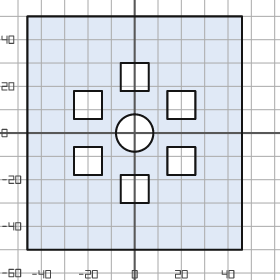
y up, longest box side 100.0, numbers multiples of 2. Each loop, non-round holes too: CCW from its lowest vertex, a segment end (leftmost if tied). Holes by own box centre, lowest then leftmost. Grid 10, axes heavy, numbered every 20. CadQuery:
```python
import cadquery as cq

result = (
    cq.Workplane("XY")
    .moveTo(-46.0, -50.0)
    .lineTo(46.0, -50.0)
    .lineTo(46.0, 50.0)
    .lineTo(-46.0, 50.0)
    .close()
    .moveTo(-6.0, -30.0)
    .lineTo(6.0, -30.0)
    .lineTo(6.0, -18.0)
    .lineTo(-6.0, -18.0)
    .close()
    .moveTo(-26.0, -18.0)
    .lineTo(-14.0, -18.0)
    .lineTo(-14.0, -6.0)
    .lineTo(-26.0, -6.0)
    .close()
    .moveTo(14.0, -18.0)
    .lineTo(26.0, -18.0)
    .lineTo(26.0, -6.0)
    .lineTo(14.0, -6.0)
    .close()
    .moveTo(0.0, 0.0)
    .circle(8.0)
    .moveTo(-26.0, 6.0)
    .lineTo(-14.0, 6.0)
    .lineTo(-14.0, 18.0)
    .lineTo(-26.0, 18.0)
    .close()
    .moveTo(14.0, 6.0)
    .lineTo(26.0, 6.0)
    .lineTo(26.0, 18.0)
    .lineTo(14.0, 18.0)
    .close()
    .moveTo(-6.0, 18.0)
    .lineTo(6.0, 18.0)
    .lineTo(6.0, 30.0)
    .lineTo(-6.0, 30.0)
    .close()
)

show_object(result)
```